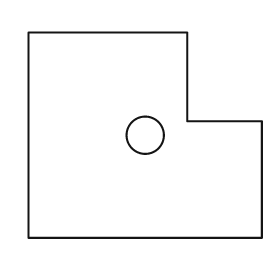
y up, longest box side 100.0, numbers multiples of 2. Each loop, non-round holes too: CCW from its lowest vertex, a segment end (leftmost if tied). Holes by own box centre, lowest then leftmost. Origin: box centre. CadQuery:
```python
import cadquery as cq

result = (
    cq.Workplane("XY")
    .moveTo(-50.0, -44.0)
    .lineTo(50.0, -44.0)
    .lineTo(50.0, 6.0)
    .lineTo(18.0, 6.0)
    .lineTo(18.0, 44.0)
    .lineTo(-50.0, 44.0)
    .close()
    .moveTo(0.0, 0.0)
    .circle(8.0)
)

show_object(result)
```